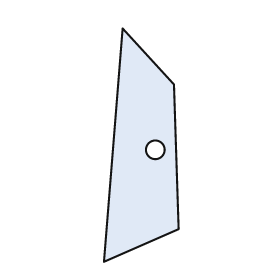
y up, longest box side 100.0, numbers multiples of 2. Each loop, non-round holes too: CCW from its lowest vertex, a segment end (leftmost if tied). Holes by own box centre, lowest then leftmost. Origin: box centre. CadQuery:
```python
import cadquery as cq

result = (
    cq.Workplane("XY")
    .moveTo(-16.0, -50.0)
    .lineTo(16.0, -36.0)
    .lineTo(14.0, 26.0)
    .lineTo(-8.0, 50.0)
    .close()
    .moveTo(6.0, -2.0)
    .circle(4.0)
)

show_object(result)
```